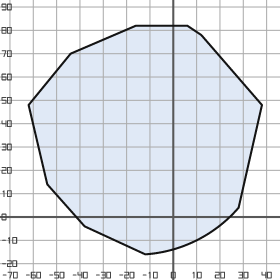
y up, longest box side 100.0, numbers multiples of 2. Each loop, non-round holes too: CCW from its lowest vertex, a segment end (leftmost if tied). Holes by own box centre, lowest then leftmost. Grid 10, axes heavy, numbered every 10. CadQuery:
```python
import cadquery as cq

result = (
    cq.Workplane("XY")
    .moveTo(-12.0, -16.0)
    .threePointArc((10.0, -10.0), (28.0, 4.0))
    .lineTo(38.0, 48.0)
    .lineTo(12.0, 78.0)
    .lineTo(6.0, 82.0)
    .lineTo(-16.0, 82.0)
    .lineTo(-44.0, 70.0)
    .lineTo(-62.0, 48.0)
    .lineTo(-54.0, 14.0)
    .lineTo(-38.0, -4.0)
    .close()
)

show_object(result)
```